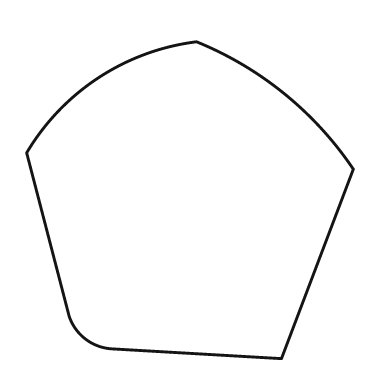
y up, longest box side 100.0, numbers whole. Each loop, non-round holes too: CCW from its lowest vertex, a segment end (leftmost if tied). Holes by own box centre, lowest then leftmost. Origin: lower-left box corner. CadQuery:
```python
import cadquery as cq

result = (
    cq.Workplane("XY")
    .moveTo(78.0, 0.0)
    .lineTo(100.0, 58.0)
    .threePointArc((79.0, 81.0), (52.0, 97.0))
    .threePointArc((22.0, 86.0), (0.0, 63.0))
    .lineTo(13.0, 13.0)
    .threePointArc((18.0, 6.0), (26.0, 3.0))
    .close()
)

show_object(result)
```